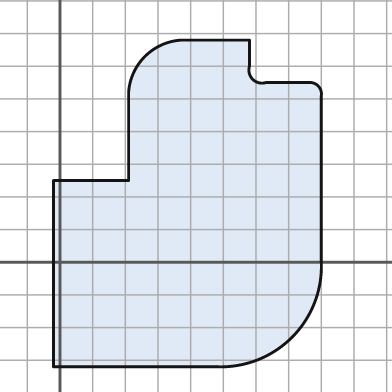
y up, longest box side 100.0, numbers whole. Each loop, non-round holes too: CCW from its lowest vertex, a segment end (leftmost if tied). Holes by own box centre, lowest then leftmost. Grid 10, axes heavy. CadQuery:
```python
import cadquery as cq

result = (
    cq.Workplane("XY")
    .moveTo(-2.0, -32.0)
    .lineTo(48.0, -32.0)
    .threePointArc((71.0, -23.0), (80.0, 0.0))
    .lineTo(80.0, 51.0)
    .threePointArc((79.0, 54.0), (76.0, 55.0))
    .lineTo(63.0, 55.0)
    .threePointArc((59.0, 56.0), (58.0, 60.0))
    .lineTo(58.0, 68.0)
    .lineTo(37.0, 68.0)
    .threePointArc((26.0, 63.0), (21.0, 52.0))
    .lineTo(21.0, 25.0)
    .lineTo(-2.0, 25.0)
    .close()
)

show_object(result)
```